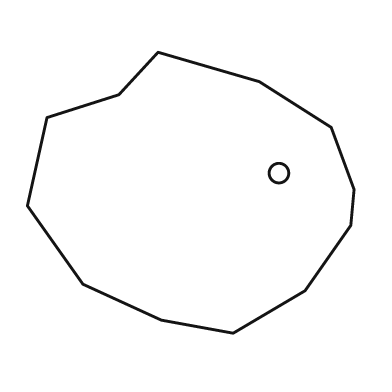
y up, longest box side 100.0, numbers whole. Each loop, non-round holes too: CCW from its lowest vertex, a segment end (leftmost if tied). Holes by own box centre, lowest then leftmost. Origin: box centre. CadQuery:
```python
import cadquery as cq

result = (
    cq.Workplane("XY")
    .moveTo(13.0, -43.0)
    .lineTo(35.0, -30.0)
    .lineTo(49.0, -10.0)
    .lineTo(50.0, 1.0)
    .lineTo(43.0, 20.0)
    .lineTo(21.0, 34.0)
    .lineTo(-10.0, 43.0)
    .lineTo(-22.0, 30.0)
    .lineTo(-44.0, 23.0)
    .lineTo(-50.0, -4.0)
    .lineTo(-33.0, -28.0)
    .lineTo(-9.0, -39.0)
    .close()
    .moveTo(27.0, 6.0)
    .circle(3.0)
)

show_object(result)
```